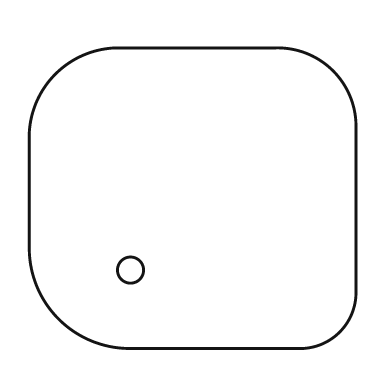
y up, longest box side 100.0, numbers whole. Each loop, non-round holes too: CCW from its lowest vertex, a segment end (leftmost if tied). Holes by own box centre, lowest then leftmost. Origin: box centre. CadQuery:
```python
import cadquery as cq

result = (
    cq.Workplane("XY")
    .moveTo(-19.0, -46.0)
    .lineTo(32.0, -46.0)
    .threePointArc((45.0, -41.0), (50.0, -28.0))
    .lineTo(50.0, 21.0)
    .threePointArc((43.0, 39.0), (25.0, 46.0))
    .lineTo(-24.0, 46.0)
    .threePointArc((-42.0, 38.0), (-50.0, 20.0))
    .lineTo(-50.0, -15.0)
    .threePointArc((-41.0, -37.0), (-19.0, -46.0))
    .close()
    .moveTo(-19.0, -22.0)
    .circle(4.0)
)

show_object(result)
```